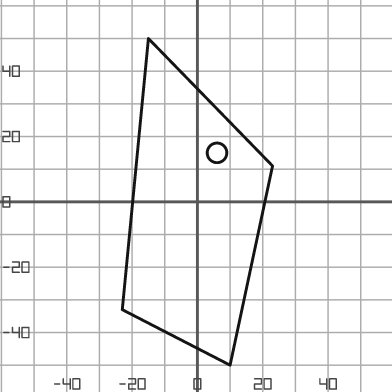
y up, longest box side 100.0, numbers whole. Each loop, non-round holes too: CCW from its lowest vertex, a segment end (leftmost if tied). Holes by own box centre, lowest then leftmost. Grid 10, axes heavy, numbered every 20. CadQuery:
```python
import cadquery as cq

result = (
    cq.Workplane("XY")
    .moveTo(10.0, -50.0)
    .lineTo(23.0, 11.0)
    .lineTo(-15.0, 50.0)
    .lineTo(-23.0, -33.0)
    .close()
    .moveTo(6.0, 15.0)
    .circle(3.0)
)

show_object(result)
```